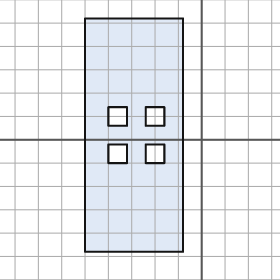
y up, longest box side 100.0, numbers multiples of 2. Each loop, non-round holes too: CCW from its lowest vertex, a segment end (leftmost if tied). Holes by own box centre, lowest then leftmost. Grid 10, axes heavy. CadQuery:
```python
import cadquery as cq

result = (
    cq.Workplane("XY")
    .moveTo(-50.0, -48.0)
    .lineTo(-8.0, -48.0)
    .lineTo(-8.0, 52.0)
    .lineTo(-50.0, 52.0)
    .close()
    .moveTo(-40.0, -10.0)
    .lineTo(-32.0, -10.0)
    .lineTo(-32.0, -2.0)
    .lineTo(-40.0, -2.0)
    .close()
    .moveTo(-24.0, -10.0)
    .lineTo(-16.0, -10.0)
    .lineTo(-16.0, -2.0)
    .lineTo(-24.0, -2.0)
    .close()
    .moveTo(-40.0, 6.0)
    .lineTo(-32.0, 6.0)
    .lineTo(-32.0, 14.0)
    .lineTo(-40.0, 14.0)
    .close()
    .moveTo(-24.0, 6.0)
    .lineTo(-16.0, 6.0)
    .lineTo(-16.0, 14.0)
    .lineTo(-24.0, 14.0)
    .close()
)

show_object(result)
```